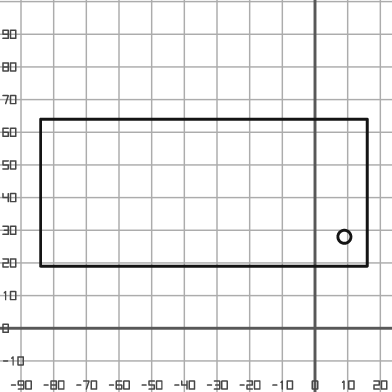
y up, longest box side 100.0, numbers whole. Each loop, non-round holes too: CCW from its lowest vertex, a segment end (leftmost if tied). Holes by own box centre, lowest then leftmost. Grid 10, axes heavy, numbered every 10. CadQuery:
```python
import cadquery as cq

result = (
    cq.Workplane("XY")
    .moveTo(-84.0, 19.0)
    .lineTo(16.0, 19.0)
    .lineTo(16.0, 64.0)
    .lineTo(-84.0, 64.0)
    .close()
    .moveTo(9.0, 28.0)
    .circle(2.0)
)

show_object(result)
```